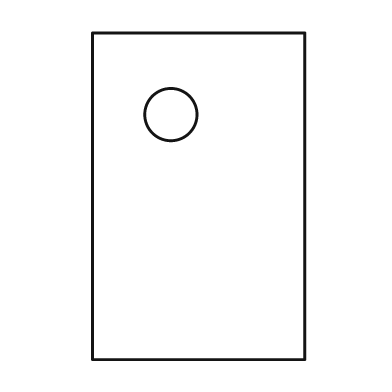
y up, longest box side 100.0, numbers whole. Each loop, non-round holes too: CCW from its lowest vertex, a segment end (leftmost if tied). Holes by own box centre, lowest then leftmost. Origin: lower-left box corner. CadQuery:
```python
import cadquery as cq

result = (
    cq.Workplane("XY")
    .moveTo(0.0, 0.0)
    .lineTo(65.0, 0.0)
    .lineTo(65.0, 100.0)
    .lineTo(0.0, 100.0)
    .close()
    .moveTo(24.0, 75.0)
    .circle(8.0)
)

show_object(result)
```